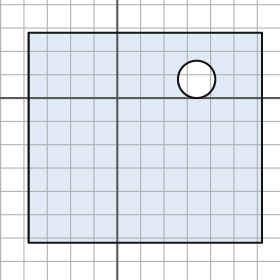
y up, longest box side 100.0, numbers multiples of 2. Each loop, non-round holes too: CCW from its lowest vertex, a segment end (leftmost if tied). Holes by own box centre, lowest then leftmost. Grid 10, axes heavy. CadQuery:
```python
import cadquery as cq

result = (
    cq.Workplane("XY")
    .moveTo(-38.0, -62.0)
    .lineTo(62.0, -62.0)
    .lineTo(62.0, 28.0)
    .lineTo(-38.0, 28.0)
    .close()
    .moveTo(34.0, 8.0)
    .circle(8.0)
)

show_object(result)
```